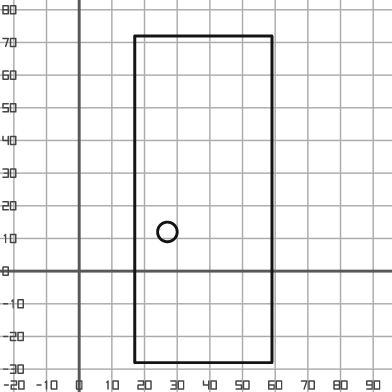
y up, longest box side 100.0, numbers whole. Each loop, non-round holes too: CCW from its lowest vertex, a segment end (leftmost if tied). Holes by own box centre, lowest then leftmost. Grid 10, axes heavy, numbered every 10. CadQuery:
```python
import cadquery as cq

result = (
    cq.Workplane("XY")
    .moveTo(17.0, -28.0)
    .lineTo(59.0, -28.0)
    .lineTo(59.0, 72.0)
    .lineTo(17.0, 72.0)
    .close()
    .moveTo(27.0, 12.0)
    .circle(3.0)
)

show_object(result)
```